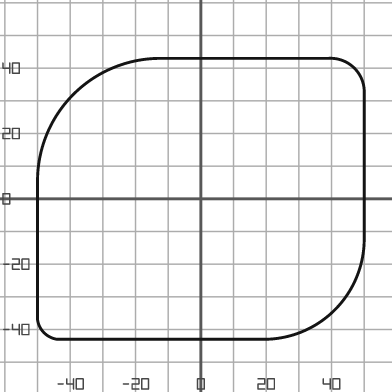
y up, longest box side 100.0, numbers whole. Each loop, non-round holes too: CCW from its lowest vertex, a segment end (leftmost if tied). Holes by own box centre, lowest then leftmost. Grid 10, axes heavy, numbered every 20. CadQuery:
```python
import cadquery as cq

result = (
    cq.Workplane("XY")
    .moveTo(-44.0, -43.0)
    .lineTo(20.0, -43.0)
    .threePointArc((41.0, -34.0), (50.0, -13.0))
    .lineTo(50.0, 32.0)
    .threePointArc((47.0, 40.0), (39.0, 43.0))
    .lineTo(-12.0, 43.0)
    .threePointArc((-39.0, 32.0), (-50.0, 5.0))
    .lineTo(-50.0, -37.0)
    .threePointArc((-48.0, -41.0), (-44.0, -43.0))
    .close()
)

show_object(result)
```